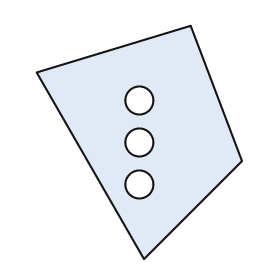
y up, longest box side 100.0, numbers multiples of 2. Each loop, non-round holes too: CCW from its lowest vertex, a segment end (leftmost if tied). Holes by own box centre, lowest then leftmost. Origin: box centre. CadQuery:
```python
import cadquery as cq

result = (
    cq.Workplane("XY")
    .moveTo(2.0, -50.0)
    .lineTo(44.0, -8.0)
    .lineTo(22.0, 50.0)
    .lineTo(-44.0, 30.0)
    .close()
    .moveTo(0.0, -18.0)
    .circle(6.0)
    .moveTo(0.0, 0.0)
    .circle(6.0)
    .moveTo(0.0, 18.0)
    .circle(6.0)
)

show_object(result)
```